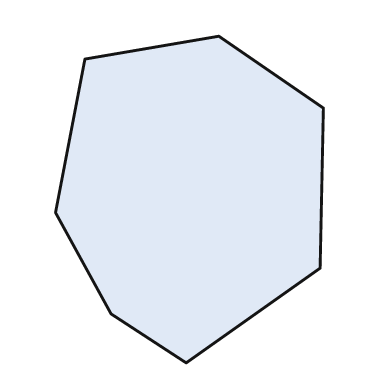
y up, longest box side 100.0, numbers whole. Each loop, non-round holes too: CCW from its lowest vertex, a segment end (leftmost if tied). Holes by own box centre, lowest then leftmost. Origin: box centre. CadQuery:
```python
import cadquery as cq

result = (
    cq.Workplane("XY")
    .moveTo(-1.0, -50.0)
    .lineTo(40.0, -21.0)
    .lineTo(41.0, 28.0)
    .lineTo(9.0, 50.0)
    .lineTo(-32.0, 43.0)
    .lineTo(-41.0, -4.0)
    .lineTo(-24.0, -35.0)
    .close()
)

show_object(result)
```